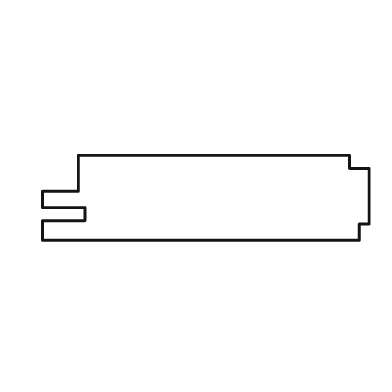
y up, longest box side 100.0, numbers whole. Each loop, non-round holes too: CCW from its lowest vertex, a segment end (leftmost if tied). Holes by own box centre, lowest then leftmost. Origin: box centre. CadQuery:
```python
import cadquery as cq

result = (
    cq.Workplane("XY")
    .moveTo(-50.0, -13.0)
    .lineTo(47.0, -13.0)
    .lineTo(47.0, -8.0)
    .lineTo(50.0, -8.0)
    .lineTo(50.0, 9.0)
    .lineTo(44.0, 9.0)
    .lineTo(44.0, 13.0)
    .lineTo(-39.0, 13.0)
    .lineTo(-39.0, 2.0)
    .lineTo(-50.0, 2.0)
    .lineTo(-50.0, -3.0)
    .lineTo(-37.0, -3.0)
    .lineTo(-37.0, -7.0)
    .lineTo(-50.0, -7.0)
    .close()
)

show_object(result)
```